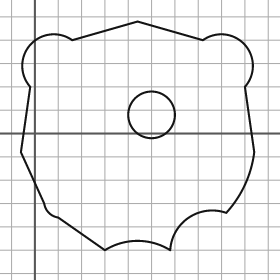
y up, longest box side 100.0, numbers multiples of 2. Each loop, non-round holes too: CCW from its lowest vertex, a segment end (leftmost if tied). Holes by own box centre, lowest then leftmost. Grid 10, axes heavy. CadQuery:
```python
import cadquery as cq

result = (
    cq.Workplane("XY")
    .moveTo(30.0, -50.0)
    .threePointArc((44.0, -46.0), (58.0, -50.0))
    .threePointArc((66.0, -36.0), (82.0, -34.0))
    .threePointArc((90.0, -22.0), (94.0, -8.0))
    .lineTo(90.0, 20.0)
    .threePointArc((90.0, 38.0), (72.0, 40.0))
    .lineTo(44.0, 48.0)
    .lineTo(16.0, 40.0)
    .threePointArc((-2.0, 38.0), (-2.0, 20.0))
    .lineTo(-6.0, -8.0)
    .lineTo(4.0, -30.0)
    .threePointArc((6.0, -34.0), (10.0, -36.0))
    .close()
    .moveTo(50.0, 8.0)
    .circle(10.0)
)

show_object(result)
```